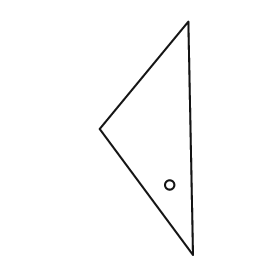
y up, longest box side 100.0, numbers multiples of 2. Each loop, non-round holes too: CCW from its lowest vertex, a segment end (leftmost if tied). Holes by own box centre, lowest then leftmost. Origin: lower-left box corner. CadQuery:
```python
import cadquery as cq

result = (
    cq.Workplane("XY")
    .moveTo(40.0, 0.0)
    .lineTo(38.0, 100.0)
    .lineTo(0.0, 54.0)
    .close()
    .moveTo(30.0, 30.0)
    .circle(2.0)
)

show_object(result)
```